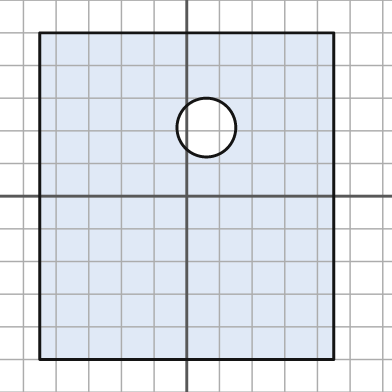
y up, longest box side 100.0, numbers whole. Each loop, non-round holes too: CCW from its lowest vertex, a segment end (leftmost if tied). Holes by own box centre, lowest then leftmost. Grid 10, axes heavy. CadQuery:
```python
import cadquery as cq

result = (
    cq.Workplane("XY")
    .moveTo(-45.0, -50.0)
    .lineTo(45.0, -50.0)
    .lineTo(45.0, 50.0)
    .lineTo(-45.0, 50.0)
    .close()
    .moveTo(6.0, 21.0)
    .circle(9.0)
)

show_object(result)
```